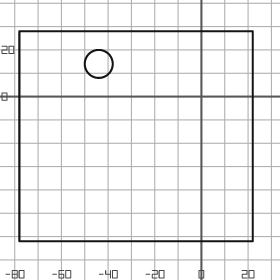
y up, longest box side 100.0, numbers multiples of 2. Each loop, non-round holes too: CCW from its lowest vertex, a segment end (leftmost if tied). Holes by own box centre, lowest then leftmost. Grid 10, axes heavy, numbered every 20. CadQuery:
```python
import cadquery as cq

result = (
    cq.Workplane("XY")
    .moveTo(-78.0, -62.0)
    .lineTo(22.0, -62.0)
    .lineTo(22.0, 28.0)
    .lineTo(-78.0, 28.0)
    .close()
    .moveTo(-44.0, 14.0)
    .circle(6.0)
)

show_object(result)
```